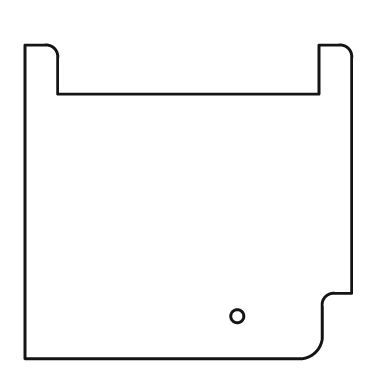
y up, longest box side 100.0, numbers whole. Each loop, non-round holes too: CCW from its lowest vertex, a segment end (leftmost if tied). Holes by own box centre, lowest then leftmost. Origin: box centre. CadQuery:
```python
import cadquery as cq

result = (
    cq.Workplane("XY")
    .moveTo(-50.0, -48.0)
    .lineTo(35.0, -48.0)
    .threePointArc((39.0, -46.0), (41.0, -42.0))
    .lineTo(41.0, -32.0)
    .threePointArc((42.0, -29.0), (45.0, -28.0))
    .lineTo(50.0, -28.0)
    .lineTo(50.0, 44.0)
    .threePointArc((49.0, 47.0), (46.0, 48.0))
    .lineTo(40.0, 48.0)
    .lineTo(40.0, 33.0)
    .lineTo(-40.0, 33.0)
    .lineTo(-40.0, 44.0)
    .threePointArc((-41.0, 47.0), (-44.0, 48.0))
    .lineTo(-50.0, 48.0)
    .close()
    .moveTo(15.0, -35.0)
    .circle(2.0)
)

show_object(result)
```